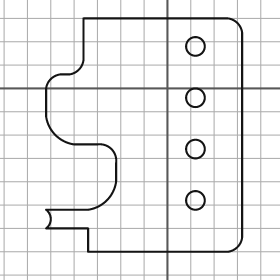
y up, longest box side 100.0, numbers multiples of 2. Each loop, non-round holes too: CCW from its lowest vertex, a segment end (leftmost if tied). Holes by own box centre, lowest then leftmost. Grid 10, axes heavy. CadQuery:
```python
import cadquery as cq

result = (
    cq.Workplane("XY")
    .moveTo(-34.0, -70.0)
    .lineTo(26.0, -70.0)
    .threePointArc((30.0, -68.0), (32.0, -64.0))
    .lineTo(32.0, 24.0)
    .threePointArc((30.0, 28.0), (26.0, 30.0))
    .lineTo(-36.0, 30.0)
    .lineTo(-36.0, 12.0)
    .threePointArc((-38.0, 8.0), (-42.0, 6.0))
    .lineTo(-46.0, 6.0)
    .threePointArc((-50.0, 4.0), (-52.0, 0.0))
    .lineTo(-52.0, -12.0)
    .threePointArc((-48.0, -20.0), (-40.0, -24.0))
    .lineTo(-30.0, -24.0)
    .threePointArc((-24.0, -26.0), (-22.0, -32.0))
    .lineTo(-22.0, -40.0)
    .threePointArc((-26.0, -48.0), (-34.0, -52.0))
    .lineTo(-52.0, -52.0)
    .threePointArc((-50.0, -56.0), (-52.0, -60.0))
    .lineTo(-34.0, -60.0)
    .close()
    .moveTo(12.0, -48.0)
    .circle(4.0)
    .moveTo(12.0, -26.0)
    .circle(4.0)
    .moveTo(12.0, -4.0)
    .circle(4.0)
    .moveTo(12.0, 18.0)
    .circle(4.0)
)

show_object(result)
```